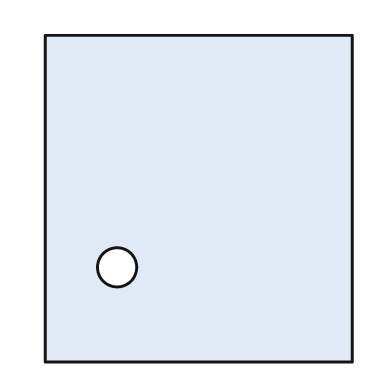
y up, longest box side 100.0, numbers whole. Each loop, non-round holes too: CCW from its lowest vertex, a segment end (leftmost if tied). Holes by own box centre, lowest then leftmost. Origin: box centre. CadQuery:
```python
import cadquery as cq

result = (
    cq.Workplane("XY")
    .moveTo(-47.0, -50.0)
    .lineTo(47.0, -50.0)
    .lineTo(47.0, 50.0)
    .lineTo(-47.0, 50.0)
    .close()
    .moveTo(-25.0, -21.0)
    .circle(6.0)
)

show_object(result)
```